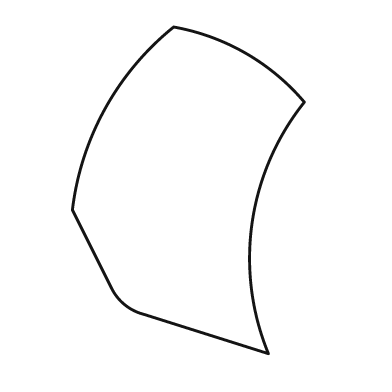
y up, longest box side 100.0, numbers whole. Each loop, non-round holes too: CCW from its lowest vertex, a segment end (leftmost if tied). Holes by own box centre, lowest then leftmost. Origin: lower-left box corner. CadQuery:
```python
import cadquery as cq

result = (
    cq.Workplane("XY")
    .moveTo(60.0, 0.0)
    .threePointArc((55.0, 40.0), (71.0, 77.0))
    .threePointArc((53.0, 92.0), (31.0, 100.0))
    .threePointArc((10.0, 75.0), (0.0, 44.0))
    .lineTo(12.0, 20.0)
    .threePointArc((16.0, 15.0), (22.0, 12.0))
    .close()
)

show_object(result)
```